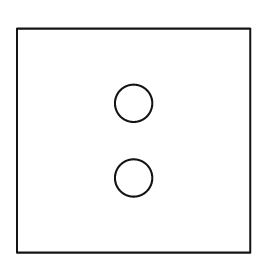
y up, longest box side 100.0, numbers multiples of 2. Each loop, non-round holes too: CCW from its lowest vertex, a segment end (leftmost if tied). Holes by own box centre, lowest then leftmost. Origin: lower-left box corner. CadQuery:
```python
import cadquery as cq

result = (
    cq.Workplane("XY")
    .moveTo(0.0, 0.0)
    .lineTo(100.0, 0.0)
    .lineTo(100.0, 96.0)
    .lineTo(0.0, 96.0)
    .close()
    .moveTo(50.0, 32.0)
    .circle(8.0)
    .moveTo(50.0, 64.0)
    .circle(8.0)
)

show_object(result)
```